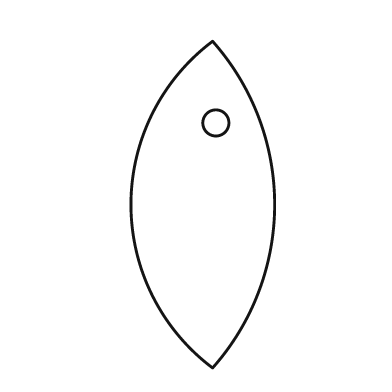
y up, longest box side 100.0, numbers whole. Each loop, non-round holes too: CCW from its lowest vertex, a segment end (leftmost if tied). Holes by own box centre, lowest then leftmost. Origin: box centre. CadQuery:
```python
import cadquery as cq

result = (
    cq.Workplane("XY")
    .moveTo(3.0, -50.0)
    .threePointArc((22.0, 0.0), (3.0, 50.0))
    .threePointArc((-22.0, 0.0), (3.0, -50.0))
    .close()
    .moveTo(4.0, 25.0)
    .circle(4.0)
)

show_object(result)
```